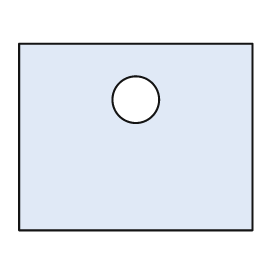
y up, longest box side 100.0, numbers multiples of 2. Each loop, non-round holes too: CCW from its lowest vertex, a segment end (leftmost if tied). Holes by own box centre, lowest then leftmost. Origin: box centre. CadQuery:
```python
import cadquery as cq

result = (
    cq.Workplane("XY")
    .moveTo(-50.0, -40.0)
    .lineTo(50.0, -40.0)
    .lineTo(50.0, 40.0)
    .lineTo(-50.0, 40.0)
    .close()
    .moveTo(0.0, 16.0)
    .circle(10.0)
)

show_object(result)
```